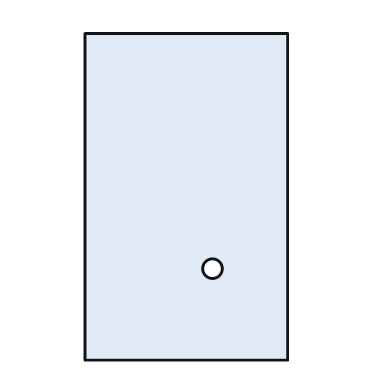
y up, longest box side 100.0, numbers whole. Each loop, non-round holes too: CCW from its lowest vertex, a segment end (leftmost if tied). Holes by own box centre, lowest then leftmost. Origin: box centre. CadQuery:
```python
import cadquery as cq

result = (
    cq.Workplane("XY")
    .moveTo(-31.0, -50.0)
    .lineTo(31.0, -50.0)
    .lineTo(31.0, 50.0)
    .lineTo(-31.0, 50.0)
    .close()
    .moveTo(8.0, -22.0)
    .circle(3.0)
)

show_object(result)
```